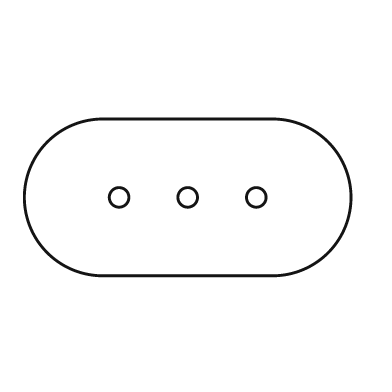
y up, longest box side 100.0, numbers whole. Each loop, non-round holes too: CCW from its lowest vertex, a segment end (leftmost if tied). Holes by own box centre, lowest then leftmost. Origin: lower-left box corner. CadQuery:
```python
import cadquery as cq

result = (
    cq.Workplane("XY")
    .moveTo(24.0, 0.0)
    .lineTo(76.0, 0.0)
    .threePointArc((100.0, 24.0), (76.0, 48.0))
    .lineTo(24.0, 48.0)
    .threePointArc((0.0, 24.0), (24.0, 0.0))
    .close()
    .moveTo(29.0, 24.0)
    .circle(3.0)
    .moveTo(50.0, 24.0)
    .circle(3.0)
    .moveTo(71.0, 24.0)
    .circle(3.0)
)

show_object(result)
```